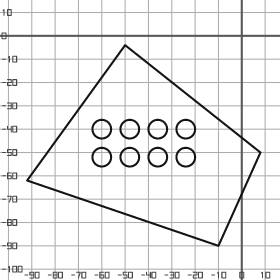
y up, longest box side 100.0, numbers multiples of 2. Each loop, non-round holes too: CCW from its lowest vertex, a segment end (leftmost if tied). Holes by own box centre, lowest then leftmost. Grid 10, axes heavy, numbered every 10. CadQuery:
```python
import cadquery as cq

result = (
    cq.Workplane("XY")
    .moveTo(-10.0, -90.0)
    .lineTo(8.0, -50.0)
    .lineTo(-50.0, -4.0)
    .lineTo(-92.0, -62.0)
    .close()
    .moveTo(-60.0, -52.0)
    .circle(4.0)
    .moveTo(-48.0, -52.0)
    .circle(4.0)
    .moveTo(-36.0, -52.0)
    .circle(4.0)
    .moveTo(-24.0, -52.0)
    .circle(4.0)
    .moveTo(-60.0, -40.0)
    .circle(4.0)
    .moveTo(-48.0, -40.0)
    .circle(4.0)
    .moveTo(-36.0, -40.0)
    .circle(4.0)
    .moveTo(-24.0, -40.0)
    .circle(4.0)
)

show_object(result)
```